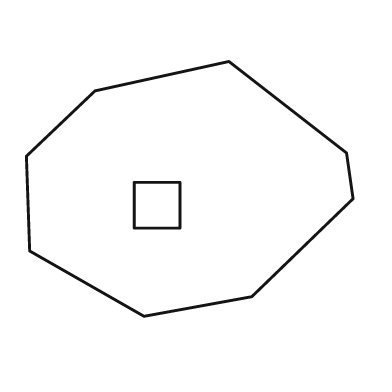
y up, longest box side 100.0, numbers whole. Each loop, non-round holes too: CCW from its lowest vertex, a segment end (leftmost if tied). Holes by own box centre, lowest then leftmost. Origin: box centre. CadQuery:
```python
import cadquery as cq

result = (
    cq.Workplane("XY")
    .moveTo(-14.0, -39.0)
    .lineTo(19.0, -33.0)
    .lineTo(50.0, -3.0)
    .lineTo(48.0, 11.0)
    .lineTo(12.0, 39.0)
    .lineTo(-29.0, 30.0)
    .lineTo(-50.0, 10.0)
    .lineTo(-49.0, -19.0)
    .close()
    .moveTo(-17.0, -12.0)
    .lineTo(-3.0, -12.0)
    .lineTo(-3.0, 2.0)
    .lineTo(-17.0, 2.0)
    .close()
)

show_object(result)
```